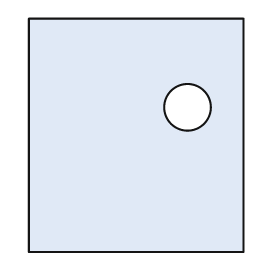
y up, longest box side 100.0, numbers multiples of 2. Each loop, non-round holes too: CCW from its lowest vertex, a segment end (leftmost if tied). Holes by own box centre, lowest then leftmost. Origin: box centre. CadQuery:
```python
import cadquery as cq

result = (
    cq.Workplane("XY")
    .moveTo(-46.0, -50.0)
    .lineTo(46.0, -50.0)
    .lineTo(46.0, 50.0)
    .lineTo(-46.0, 50.0)
    .close()
    .moveTo(22.0, 12.0)
    .circle(10.0)
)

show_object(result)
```